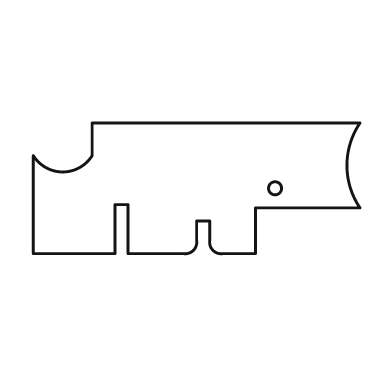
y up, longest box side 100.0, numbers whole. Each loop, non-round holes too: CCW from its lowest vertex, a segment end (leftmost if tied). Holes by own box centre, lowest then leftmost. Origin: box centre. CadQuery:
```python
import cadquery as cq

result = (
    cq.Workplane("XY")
    .moveTo(-50.0, -20.0)
    .lineTo(-25.0, -20.0)
    .lineTo(-25.0, -5.0)
    .lineTo(-21.0, -5.0)
    .lineTo(-21.0, -20.0)
    .lineTo(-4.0, -20.0)
    .threePointArc((-1.0, -19.0), (0.0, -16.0))
    .lineTo(0.0, -10.0)
    .lineTo(4.0, -10.0)
    .lineTo(4.0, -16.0)
    .threePointArc((5.0, -19.0), (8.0, -20.0))
    .lineTo(18.0, -20.0)
    .lineTo(18.0, -6.0)
    .lineTo(50.0, -6.0)
    .threePointArc((46.0, 7.0), (50.0, 20.0))
    .lineTo(-32.0, 20.0)
    .lineTo(-32.0, 10.0)
    .threePointArc((-41.0, 5.0), (-50.0, 10.0))
    .close()
    .moveTo(24.0, 0.0)
    .circle(2.0)
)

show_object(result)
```